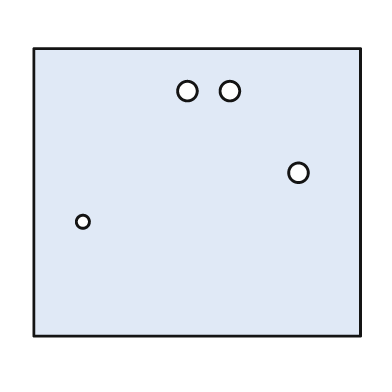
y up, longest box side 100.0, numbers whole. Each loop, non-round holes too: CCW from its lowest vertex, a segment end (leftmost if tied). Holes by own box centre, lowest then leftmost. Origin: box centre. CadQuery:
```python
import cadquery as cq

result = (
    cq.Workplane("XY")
    .moveTo(-50.0, -44.0)
    .lineTo(50.0, -44.0)
    .lineTo(50.0, 44.0)
    .lineTo(-50.0, 44.0)
    .close()
    .moveTo(-35.0, -9.0)
    .circle(2.0)
    .moveTo(31.0, 6.0)
    .circle(3.0)
    .moveTo(-3.0, 31.0)
    .circle(3.0)
    .moveTo(10.0, 31.0)
    .circle(3.0)
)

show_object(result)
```